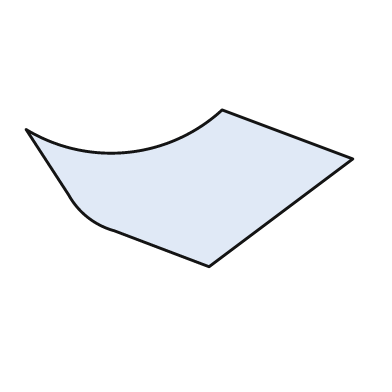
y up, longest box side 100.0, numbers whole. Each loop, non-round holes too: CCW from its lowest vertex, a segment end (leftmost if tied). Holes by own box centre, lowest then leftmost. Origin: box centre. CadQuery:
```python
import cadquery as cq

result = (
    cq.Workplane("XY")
    .moveTo(6.0, -24.0)
    .lineTo(50.0, 9.0)
    .lineTo(10.0, 24.0)
    .threePointArc((-19.0, 11.0), (-50.0, 18.0))
    .lineTo(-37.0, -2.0)
    .threePointArc((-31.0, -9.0), (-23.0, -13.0))
    .close()
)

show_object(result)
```